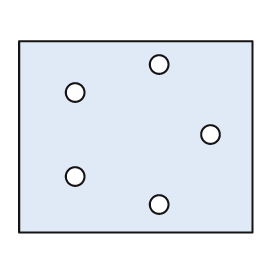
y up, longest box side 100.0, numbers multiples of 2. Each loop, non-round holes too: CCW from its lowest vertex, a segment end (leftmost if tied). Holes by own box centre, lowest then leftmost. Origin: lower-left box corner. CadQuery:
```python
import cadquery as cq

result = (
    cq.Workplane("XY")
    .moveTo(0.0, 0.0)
    .lineTo(100.0, 0.0)
    .lineTo(100.0, 82.0)
    .lineTo(0.0, 82.0)
    .close()
    .moveTo(60.0, 12.0)
    .circle(4.0)
    .moveTo(24.0, 24.0)
    .circle(4.0)
    .moveTo(82.0, 42.0)
    .circle(4.0)
    .moveTo(24.0, 60.0)
    .circle(4.0)
    .moveTo(60.0, 72.0)
    .circle(4.0)
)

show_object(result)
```